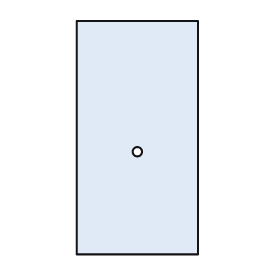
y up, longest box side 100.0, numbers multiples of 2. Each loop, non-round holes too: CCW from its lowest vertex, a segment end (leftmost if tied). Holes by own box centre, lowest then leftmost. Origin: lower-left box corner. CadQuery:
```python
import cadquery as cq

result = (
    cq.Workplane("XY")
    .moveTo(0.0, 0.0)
    .lineTo(52.0, 0.0)
    .lineTo(52.0, 100.0)
    .lineTo(0.0, 100.0)
    .close()
    .moveTo(26.0, 44.0)
    .circle(2.0)
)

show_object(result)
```